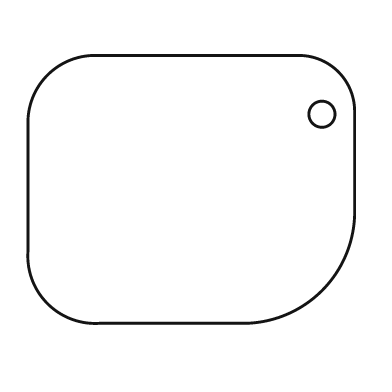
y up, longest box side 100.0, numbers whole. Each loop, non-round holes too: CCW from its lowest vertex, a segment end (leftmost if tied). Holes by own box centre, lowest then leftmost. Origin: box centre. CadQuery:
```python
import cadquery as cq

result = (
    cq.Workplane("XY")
    .moveTo(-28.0, -41.0)
    .lineTo(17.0, -41.0)
    .threePointArc((40.0, -31.0), (50.0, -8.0))
    .lineTo(50.0, 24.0)
    .threePointArc((45.0, 36.0), (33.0, 41.0))
    .lineTo(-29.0, 41.0)
    .threePointArc((-44.0, 35.0), (-50.0, 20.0))
    .lineTo(-50.0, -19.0)
    .threePointArc((-44.0, -35.0), (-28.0, -41.0))
    .close()
    .moveTo(40.0, 23.0)
    .circle(4.0)
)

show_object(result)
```